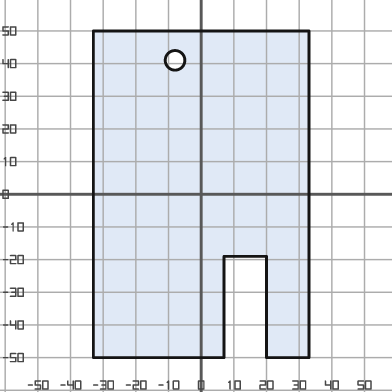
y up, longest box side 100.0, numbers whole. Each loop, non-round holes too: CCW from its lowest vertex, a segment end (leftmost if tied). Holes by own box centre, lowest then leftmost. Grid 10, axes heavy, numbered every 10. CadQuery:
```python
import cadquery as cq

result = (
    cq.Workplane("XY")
    .moveTo(-33.0, -50.0)
    .lineTo(7.0, -50.0)
    .lineTo(7.0, -19.0)
    .lineTo(20.0, -19.0)
    .lineTo(20.0, -50.0)
    .lineTo(33.0, -50.0)
    .lineTo(33.0, 50.0)
    .lineTo(-33.0, 50.0)
    .close()
    .moveTo(-8.0, 41.0)
    .circle(3.0)
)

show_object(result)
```